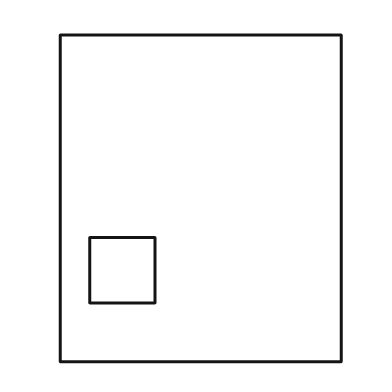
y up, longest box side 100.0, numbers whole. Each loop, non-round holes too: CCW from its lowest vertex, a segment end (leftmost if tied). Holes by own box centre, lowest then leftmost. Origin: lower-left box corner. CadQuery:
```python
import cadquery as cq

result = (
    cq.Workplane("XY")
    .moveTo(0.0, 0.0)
    .lineTo(86.0, 0.0)
    .lineTo(86.0, 100.0)
    .lineTo(0.0, 100.0)
    .close()
    .moveTo(9.0, 18.0)
    .lineTo(29.0, 18.0)
    .lineTo(29.0, 38.0)
    .lineTo(9.0, 38.0)
    .close()
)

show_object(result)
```